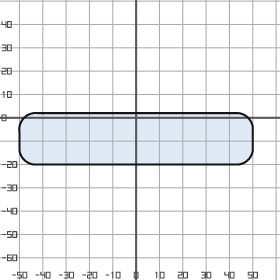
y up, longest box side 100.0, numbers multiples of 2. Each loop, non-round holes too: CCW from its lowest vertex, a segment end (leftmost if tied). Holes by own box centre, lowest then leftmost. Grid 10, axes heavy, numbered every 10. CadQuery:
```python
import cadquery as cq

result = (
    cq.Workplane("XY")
    .moveTo(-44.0, -20.0)
    .lineTo(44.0, -20.0)
    .threePointArc((48.0, -18.0), (50.0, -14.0))
    .lineTo(50.0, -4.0)
    .threePointArc((48.0, 0.0), (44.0, 2.0))
    .lineTo(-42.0, 2.0)
    .threePointArc((-48.0, 0.0), (-50.0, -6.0))
    .lineTo(-50.0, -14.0)
    .threePointArc((-48.0, -18.0), (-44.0, -20.0))
    .close()
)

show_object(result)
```